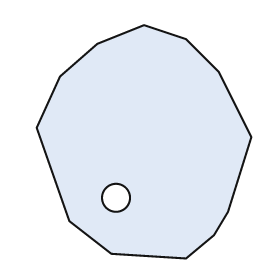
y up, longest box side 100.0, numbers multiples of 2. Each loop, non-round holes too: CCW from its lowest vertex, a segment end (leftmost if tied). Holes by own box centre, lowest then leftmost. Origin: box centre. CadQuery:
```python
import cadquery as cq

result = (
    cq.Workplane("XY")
    .moveTo(18.0, -50.0)
    .lineTo(30.0, -40.0)
    .lineTo(36.0, -30.0)
    .lineTo(46.0, 2.0)
    .lineTo(32.0, 30.0)
    .lineTo(18.0, 44.0)
    .lineTo(0.0, 50.0)
    .lineTo(-20.0, 42.0)
    .lineTo(-36.0, 28.0)
    .lineTo(-46.0, 6.0)
    .lineTo(-32.0, -34.0)
    .lineTo(-14.0, -48.0)
    .close()
    .moveTo(-12.0, -24.0)
    .circle(6.0)
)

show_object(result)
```